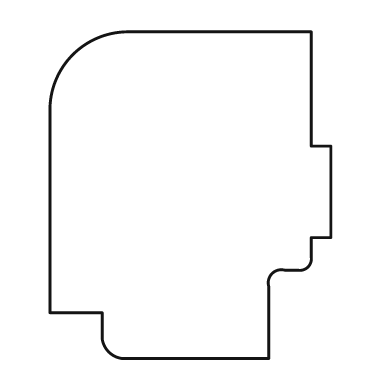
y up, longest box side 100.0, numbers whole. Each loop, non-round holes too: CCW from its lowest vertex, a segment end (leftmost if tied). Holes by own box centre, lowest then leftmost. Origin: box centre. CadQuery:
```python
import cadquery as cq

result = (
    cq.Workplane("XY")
    .moveTo(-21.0, -50.0)
    .lineTo(24.0, -50.0)
    .lineTo(24.0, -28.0)
    .threePointArc((25.0, -24.0), (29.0, -23.0))
    .lineTo(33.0, -23.0)
    .threePointArc((36.0, -22.0), (37.0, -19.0))
    .lineTo(37.0, -13.0)
    .lineTo(43.0, -13.0)
    .lineTo(43.0, 15.0)
    .lineTo(37.0, 15.0)
    .lineTo(37.0, 50.0)
    .lineTo(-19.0, 50.0)
    .threePointArc((-36.0, 43.0), (-43.0, 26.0))
    .lineTo(-43.0, -36.0)
    .lineTo(-27.0, -36.0)
    .lineTo(-27.0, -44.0)
    .threePointArc((-25.0, -48.0), (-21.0, -50.0))
    .close()
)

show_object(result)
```